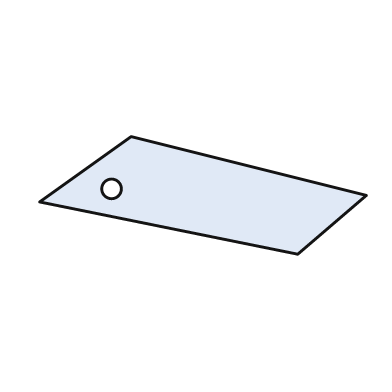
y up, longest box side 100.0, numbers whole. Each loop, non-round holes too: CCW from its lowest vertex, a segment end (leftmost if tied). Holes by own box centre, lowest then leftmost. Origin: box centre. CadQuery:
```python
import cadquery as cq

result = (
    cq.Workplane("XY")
    .moveTo(29.0, -18.0)
    .lineTo(50.0, 0.0)
    .lineTo(-22.0, 18.0)
    .lineTo(-50.0, -2.0)
    .close()
    .moveTo(-28.0, 2.0)
    .circle(3.0)
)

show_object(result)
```